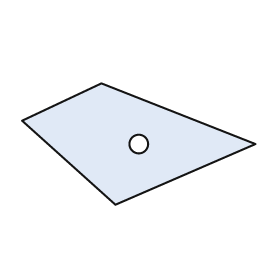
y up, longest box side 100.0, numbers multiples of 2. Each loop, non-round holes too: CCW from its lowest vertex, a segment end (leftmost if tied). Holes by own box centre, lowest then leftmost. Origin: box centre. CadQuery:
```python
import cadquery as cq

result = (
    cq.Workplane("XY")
    .moveTo(-10.0, -26.0)
    .lineTo(50.0, 0.0)
    .lineTo(-16.0, 26.0)
    .lineTo(-50.0, 10.0)
    .close()
    .moveTo(0.0, 0.0)
    .circle(4.0)
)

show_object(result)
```